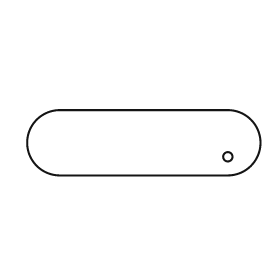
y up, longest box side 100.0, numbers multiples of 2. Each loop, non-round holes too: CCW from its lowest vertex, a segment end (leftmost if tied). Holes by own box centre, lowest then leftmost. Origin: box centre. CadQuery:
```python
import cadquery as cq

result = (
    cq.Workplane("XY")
    .moveTo(-36.0, -14.0)
    .lineTo(36.0, -14.0)
    .threePointArc((50.0, 0.0), (36.0, 14.0))
    .lineTo(-36.0, 14.0)
    .threePointArc((-50.0, 0.0), (-36.0, -14.0))
    .close()
    .moveTo(36.0, -6.0)
    .circle(2.0)
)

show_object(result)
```